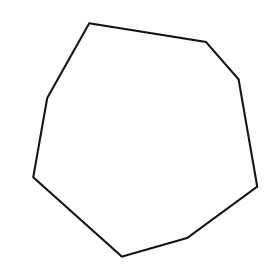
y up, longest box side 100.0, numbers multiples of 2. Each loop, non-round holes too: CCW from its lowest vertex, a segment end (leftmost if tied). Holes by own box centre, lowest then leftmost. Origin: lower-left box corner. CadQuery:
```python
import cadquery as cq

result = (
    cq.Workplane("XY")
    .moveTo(38.0, 0.0)
    .lineTo(66.0, 8.0)
    .lineTo(96.0, 30.0)
    .lineTo(88.0, 76.0)
    .lineTo(74.0, 92.0)
    .lineTo(24.0, 100.0)
    .lineTo(6.0, 68.0)
    .lineTo(0.0, 34.0)
    .close()
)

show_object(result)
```